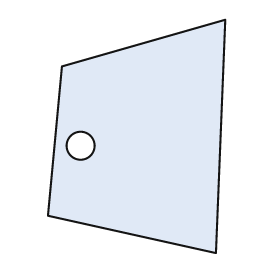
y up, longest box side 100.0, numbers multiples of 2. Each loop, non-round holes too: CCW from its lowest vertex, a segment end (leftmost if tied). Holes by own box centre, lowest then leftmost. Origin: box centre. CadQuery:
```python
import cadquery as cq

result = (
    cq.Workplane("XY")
    .moveTo(34.0, -50.0)
    .lineTo(38.0, 50.0)
    .lineTo(-32.0, 30.0)
    .lineTo(-38.0, -34.0)
    .close()
    .moveTo(-24.0, -4.0)
    .circle(6.0)
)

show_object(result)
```